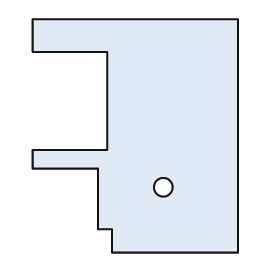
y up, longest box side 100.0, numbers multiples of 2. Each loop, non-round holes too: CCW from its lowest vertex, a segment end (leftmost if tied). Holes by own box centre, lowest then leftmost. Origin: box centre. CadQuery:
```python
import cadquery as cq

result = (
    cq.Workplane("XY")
    .moveTo(-10.0, -50.0)
    .lineTo(44.0, -50.0)
    .lineTo(44.0, 50.0)
    .lineTo(-44.0, 50.0)
    .lineTo(-44.0, 36.0)
    .lineTo(-12.0, 36.0)
    .lineTo(-12.0, -6.0)
    .lineTo(-44.0, -6.0)
    .lineTo(-44.0, -14.0)
    .lineTo(-16.0, -14.0)
    .lineTo(-16.0, -40.0)
    .lineTo(-10.0, -40.0)
    .close()
    .moveTo(12.0, -22.0)
    .circle(4.0)
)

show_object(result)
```